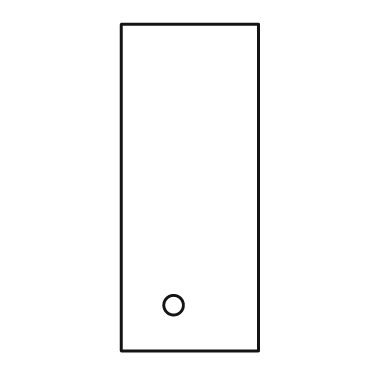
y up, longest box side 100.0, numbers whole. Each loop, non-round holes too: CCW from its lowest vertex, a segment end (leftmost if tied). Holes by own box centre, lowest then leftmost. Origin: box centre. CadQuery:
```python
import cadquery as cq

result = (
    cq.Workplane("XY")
    .moveTo(-21.0, -50.0)
    .lineTo(21.0, -50.0)
    .lineTo(21.0, 50.0)
    .lineTo(-21.0, 50.0)
    .close()
    .moveTo(-5.0, -36.0)
    .circle(3.0)
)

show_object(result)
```